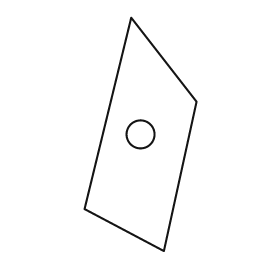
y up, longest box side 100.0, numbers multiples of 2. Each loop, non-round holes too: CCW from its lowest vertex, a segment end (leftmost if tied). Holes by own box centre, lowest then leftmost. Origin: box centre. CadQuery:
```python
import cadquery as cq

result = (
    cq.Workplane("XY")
    .moveTo(10.0, -50.0)
    .lineTo(24.0, 14.0)
    .lineTo(-4.0, 50.0)
    .lineTo(-24.0, -32.0)
    .close()
    .moveTo(0.0, 0.0)
    .circle(6.0)
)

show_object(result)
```